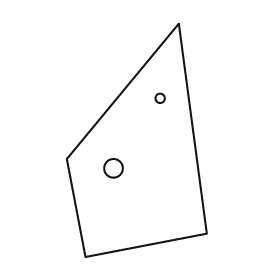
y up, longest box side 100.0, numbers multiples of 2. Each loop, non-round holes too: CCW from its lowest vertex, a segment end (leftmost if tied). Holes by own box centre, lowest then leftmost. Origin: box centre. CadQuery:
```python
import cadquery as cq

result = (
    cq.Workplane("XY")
    .moveTo(-22.0, -50.0)
    .lineTo(30.0, -40.0)
    .lineTo(18.0, 50.0)
    .lineTo(-30.0, -8.0)
    .close()
    .moveTo(-10.0, -12.0)
    .circle(4.0)
    .moveTo(10.0, 18.0)
    .circle(2.0)
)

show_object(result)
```